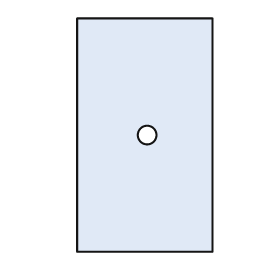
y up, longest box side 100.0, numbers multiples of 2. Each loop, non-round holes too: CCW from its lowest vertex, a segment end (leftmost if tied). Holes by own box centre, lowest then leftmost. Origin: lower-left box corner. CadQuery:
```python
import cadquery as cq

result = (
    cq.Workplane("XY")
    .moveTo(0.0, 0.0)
    .lineTo(58.0, 0.0)
    .lineTo(58.0, 100.0)
    .lineTo(0.0, 100.0)
    .close()
    .moveTo(30.0, 50.0)
    .circle(4.0)
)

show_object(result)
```